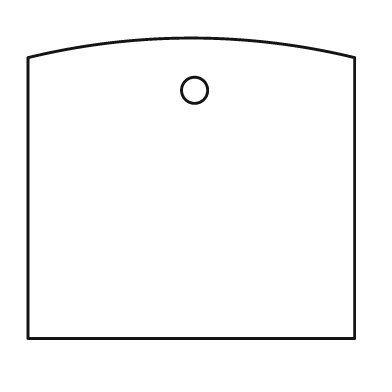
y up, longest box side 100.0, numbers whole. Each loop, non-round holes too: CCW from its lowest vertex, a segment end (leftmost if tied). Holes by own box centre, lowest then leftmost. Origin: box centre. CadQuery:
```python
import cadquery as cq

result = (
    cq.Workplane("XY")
    .moveTo(-50.0, -46.0)
    .lineTo(50.0, -46.0)
    .lineTo(50.0, 40.0)
    .threePointArc((0.0, 46.0), (-50.0, 40.0))
    .close()
    .moveTo(1.0, 30.0)
    .circle(4.0)
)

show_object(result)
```